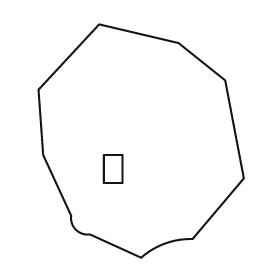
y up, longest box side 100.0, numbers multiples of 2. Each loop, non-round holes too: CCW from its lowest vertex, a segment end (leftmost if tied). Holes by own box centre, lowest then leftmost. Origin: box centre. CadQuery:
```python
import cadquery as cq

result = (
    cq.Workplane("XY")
    .moveTo(0.0, -50.0)
    .threePointArc((10.0, -44.0), (22.0, -42.0))
    .lineTo(44.0, -16.0)
    .lineTo(36.0, 26.0)
    .lineTo(16.0, 42.0)
    .lineTo(-18.0, 50.0)
    .lineTo(-44.0, 22.0)
    .lineTo(-42.0, -6.0)
    .lineTo(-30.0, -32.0)
    .threePointArc((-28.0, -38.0), (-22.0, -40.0))
    .close()
    .moveTo(-16.0, -18.0)
    .lineTo(-8.0, -18.0)
    .lineTo(-8.0, -6.0)
    .lineTo(-16.0, -6.0)
    .close()
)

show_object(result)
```